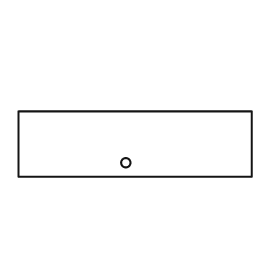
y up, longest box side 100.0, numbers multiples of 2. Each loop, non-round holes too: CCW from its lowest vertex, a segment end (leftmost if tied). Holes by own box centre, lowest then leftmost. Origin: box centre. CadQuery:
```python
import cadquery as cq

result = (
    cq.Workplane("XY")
    .moveTo(-50.0, -14.0)
    .lineTo(50.0, -14.0)
    .lineTo(50.0, 14.0)
    .lineTo(-50.0, 14.0)
    .close()
    .moveTo(-4.0, -8.0)
    .circle(2.0)
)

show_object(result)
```